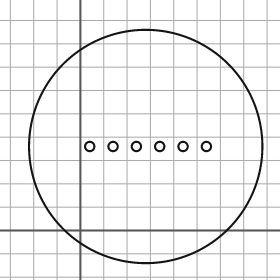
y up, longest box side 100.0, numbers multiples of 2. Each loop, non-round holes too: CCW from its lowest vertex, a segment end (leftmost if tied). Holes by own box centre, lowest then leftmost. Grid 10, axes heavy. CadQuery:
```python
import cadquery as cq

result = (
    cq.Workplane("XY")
    .moveTo(28.0, 36.0)
    .circle(50.0)
    .moveTo(4.0, 36.0)
    .circle(2.0)
    .moveTo(14.0, 36.0)
    .circle(2.0)
    .moveTo(24.0, 36.0)
    .circle(2.0)
    .moveTo(34.0, 36.0)
    .circle(2.0)
    .moveTo(44.0, 36.0)
    .circle(2.0)
    .moveTo(54.0, 36.0)
    .circle(2.0)
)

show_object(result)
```